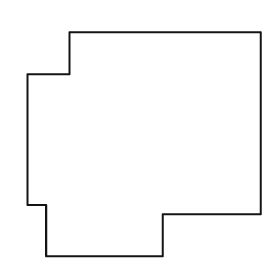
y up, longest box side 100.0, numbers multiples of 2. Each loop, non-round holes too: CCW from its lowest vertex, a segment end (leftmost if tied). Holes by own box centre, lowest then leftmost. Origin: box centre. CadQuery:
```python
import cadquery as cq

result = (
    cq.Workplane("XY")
    .moveTo(-42.0, -48.0)
    .lineTo(8.0, -48.0)
    .lineTo(8.0, -30.0)
    .lineTo(50.0, -30.0)
    .lineTo(50.0, 48.0)
    .lineTo(-32.0, 48.0)
    .lineTo(-32.0, 30.0)
    .lineTo(-50.0, 30.0)
    .lineTo(-50.0, -26.0)
    .lineTo(-42.0, -26.0)
    .close()
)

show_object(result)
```